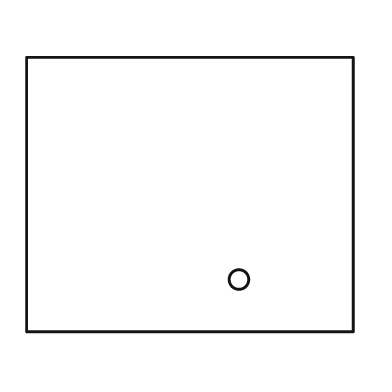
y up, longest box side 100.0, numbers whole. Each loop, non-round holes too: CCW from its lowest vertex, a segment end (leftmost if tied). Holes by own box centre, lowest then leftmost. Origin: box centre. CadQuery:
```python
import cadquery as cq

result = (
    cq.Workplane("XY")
    .moveTo(-50.0, -42.0)
    .lineTo(50.0, -42.0)
    .lineTo(50.0, 42.0)
    .lineTo(-50.0, 42.0)
    .close()
    .moveTo(15.0, -26.0)
    .circle(3.0)
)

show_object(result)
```